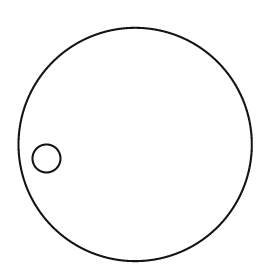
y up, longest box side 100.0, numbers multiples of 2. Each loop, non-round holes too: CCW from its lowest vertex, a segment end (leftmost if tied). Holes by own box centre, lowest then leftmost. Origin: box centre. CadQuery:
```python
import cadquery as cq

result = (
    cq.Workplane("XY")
    .moveTo(0.0, 0.0)
    .circle(50.0)
    .moveTo(-38.0, -6.0)
    .circle(6.0)
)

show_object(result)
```